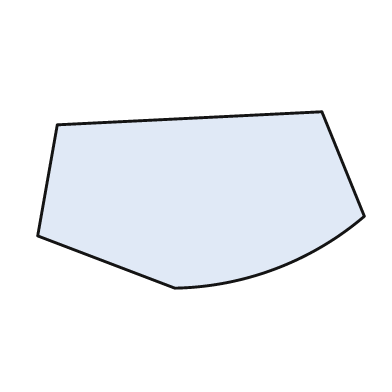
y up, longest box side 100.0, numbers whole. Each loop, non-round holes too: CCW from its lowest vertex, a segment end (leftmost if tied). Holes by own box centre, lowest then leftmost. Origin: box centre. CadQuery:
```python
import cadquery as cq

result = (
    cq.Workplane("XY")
    .moveTo(-8.0, -27.0)
    .threePointArc((23.0, -21.0), (50.0, -5.0))
    .lineTo(37.0, 27.0)
    .lineTo(-44.0, 23.0)
    .lineTo(-50.0, -11.0)
    .close()
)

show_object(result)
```